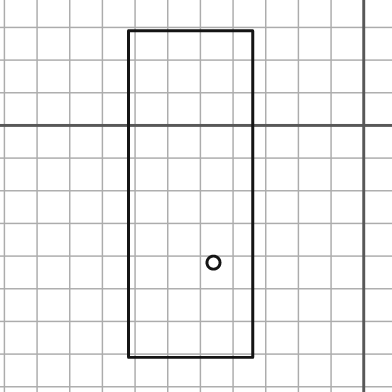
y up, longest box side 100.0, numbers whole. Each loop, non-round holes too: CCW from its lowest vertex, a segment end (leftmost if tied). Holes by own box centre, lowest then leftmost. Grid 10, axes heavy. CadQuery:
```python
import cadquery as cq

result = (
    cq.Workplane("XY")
    .moveTo(-72.0, -71.0)
    .lineTo(-34.0, -71.0)
    .lineTo(-34.0, 29.0)
    .lineTo(-72.0, 29.0)
    .close()
    .moveTo(-46.0, -42.0)
    .circle(2.0)
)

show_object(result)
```